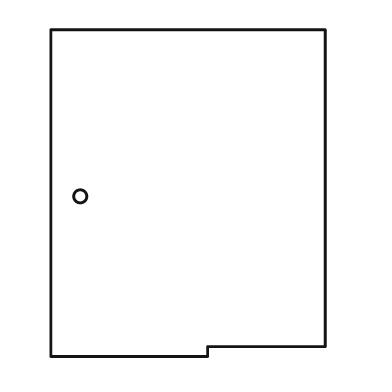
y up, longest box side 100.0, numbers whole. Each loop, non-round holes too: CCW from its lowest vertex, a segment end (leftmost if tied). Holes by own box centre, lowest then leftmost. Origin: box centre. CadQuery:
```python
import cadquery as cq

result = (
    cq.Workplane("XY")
    .moveTo(-42.0, -50.0)
    .lineTo(6.0, -50.0)
    .lineTo(6.0, -47.0)
    .lineTo(42.0, -47.0)
    .lineTo(42.0, 50.0)
    .lineTo(-42.0, 50.0)
    .close()
    .moveTo(-33.0, -1.0)
    .circle(2.0)
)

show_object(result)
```